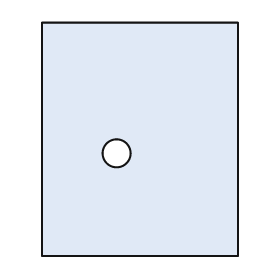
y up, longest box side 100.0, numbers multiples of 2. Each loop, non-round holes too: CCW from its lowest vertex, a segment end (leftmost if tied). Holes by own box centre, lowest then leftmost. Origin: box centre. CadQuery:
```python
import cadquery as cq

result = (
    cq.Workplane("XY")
    .moveTo(-42.0, -50.0)
    .lineTo(42.0, -50.0)
    .lineTo(42.0, 50.0)
    .lineTo(-42.0, 50.0)
    .close()
    .moveTo(-10.0, -6.0)
    .circle(6.0)
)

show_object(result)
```